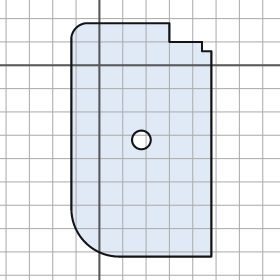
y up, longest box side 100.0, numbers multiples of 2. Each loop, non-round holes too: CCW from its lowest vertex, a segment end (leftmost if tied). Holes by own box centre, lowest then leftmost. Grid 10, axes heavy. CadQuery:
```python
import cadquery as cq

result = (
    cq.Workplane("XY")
    .moveTo(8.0, -82.0)
    .lineTo(48.0, -82.0)
    .lineTo(48.0, 6.0)
    .lineTo(44.0, 6.0)
    .lineTo(44.0, 10.0)
    .lineTo(30.0, 10.0)
    .lineTo(30.0, 18.0)
    .lineTo(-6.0, 18.0)
    .threePointArc((-10.0, 16.0), (-12.0, 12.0))
    .lineTo(-12.0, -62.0)
    .threePointArc((-6.0, -76.0), (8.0, -82.0))
    .close()
    .moveTo(18.0, -32.0)
    .circle(4.0)
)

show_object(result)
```